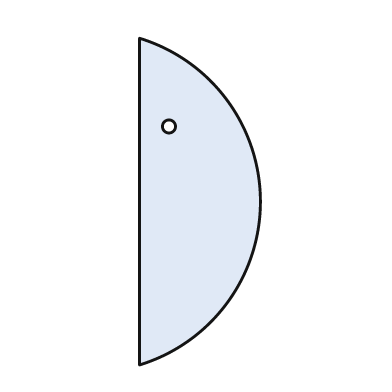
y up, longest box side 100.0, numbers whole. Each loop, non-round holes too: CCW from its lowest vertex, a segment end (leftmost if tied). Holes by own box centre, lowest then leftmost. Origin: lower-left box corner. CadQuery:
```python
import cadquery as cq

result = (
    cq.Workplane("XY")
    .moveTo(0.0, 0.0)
    .threePointArc((37.0, 50.0), (0.0, 100.0))
    .close()
    .moveTo(9.0, 73.0)
    .circle(2.0)
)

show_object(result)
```